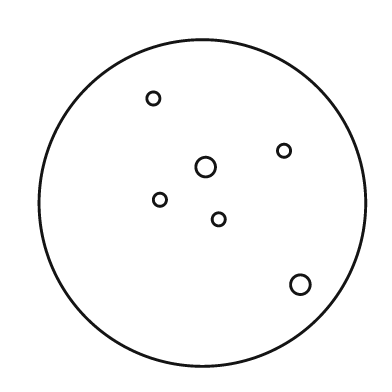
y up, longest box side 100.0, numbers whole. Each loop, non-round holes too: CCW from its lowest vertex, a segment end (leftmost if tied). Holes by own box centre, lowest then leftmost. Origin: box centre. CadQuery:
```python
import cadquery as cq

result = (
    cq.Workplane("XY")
    .moveTo(0.0, 0.0)
    .circle(50.0)
    .moveTo(30.0, -25.0)
    .circle(3.0)
    .moveTo(5.0, -5.0)
    .circle(2.0)
    .moveTo(-13.0, 1.0)
    .circle(2.0)
    .moveTo(1.0, 11.0)
    .circle(3.0)
    .moveTo(25.0, 16.0)
    .circle(2.0)
    .moveTo(-15.0, 32.0)
    .circle(2.0)
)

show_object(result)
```